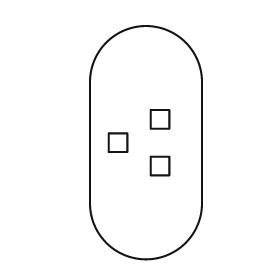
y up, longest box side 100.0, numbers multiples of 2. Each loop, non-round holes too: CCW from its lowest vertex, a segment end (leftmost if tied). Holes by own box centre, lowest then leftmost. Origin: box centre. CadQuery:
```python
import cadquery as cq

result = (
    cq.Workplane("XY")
    .moveTo(-24.0, -26.0)
    .threePointArc((0.0, -50.0), (24.0, -26.0))
    .lineTo(24.0, 26.0)
    .threePointArc((0.0, 50.0), (-24.0, 26.0))
    .close()
    .moveTo(2.0, -14.0)
    .lineTo(10.0, -14.0)
    .lineTo(10.0, -6.0)
    .lineTo(2.0, -6.0)
    .close()
    .moveTo(-16.0, -4.0)
    .lineTo(-8.0, -4.0)
    .lineTo(-8.0, 4.0)
    .lineTo(-16.0, 4.0)
    .close()
    .moveTo(2.0, 6.0)
    .lineTo(10.0, 6.0)
    .lineTo(10.0, 14.0)
    .lineTo(2.0, 14.0)
    .close()
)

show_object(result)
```